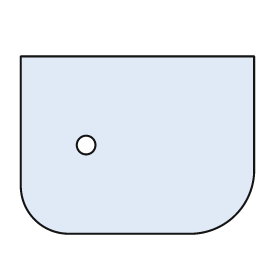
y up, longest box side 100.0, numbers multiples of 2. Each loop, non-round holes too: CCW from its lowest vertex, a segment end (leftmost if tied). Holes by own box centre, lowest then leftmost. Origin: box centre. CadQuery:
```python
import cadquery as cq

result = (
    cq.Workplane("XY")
    .moveTo(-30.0, -38.0)
    .lineTo(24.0, -38.0)
    .threePointArc((42.0, -30.0), (50.0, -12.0))
    .lineTo(50.0, 38.0)
    .lineTo(-50.0, 38.0)
    .lineTo(-50.0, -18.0)
    .threePointArc((-44.0, -32.0), (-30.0, -38.0))
    .close()
    .moveTo(-22.0, 0.0)
    .circle(4.0)
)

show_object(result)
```